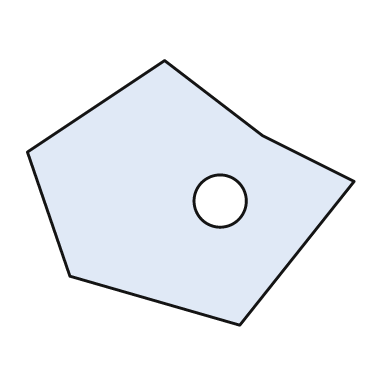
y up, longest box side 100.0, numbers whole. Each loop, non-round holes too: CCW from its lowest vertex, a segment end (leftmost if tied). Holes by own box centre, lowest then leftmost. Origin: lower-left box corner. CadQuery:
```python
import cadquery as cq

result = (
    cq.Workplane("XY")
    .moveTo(65.0, 0.0)
    .lineTo(100.0, 44.0)
    .lineTo(72.0, 58.0)
    .lineTo(42.0, 81.0)
    .lineTo(0.0, 53.0)
    .lineTo(13.0, 15.0)
    .close()
    .moveTo(59.0, 38.0)
    .circle(8.0)
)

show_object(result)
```